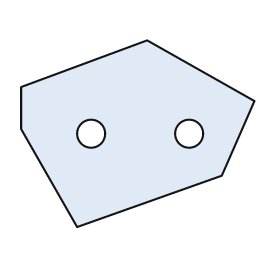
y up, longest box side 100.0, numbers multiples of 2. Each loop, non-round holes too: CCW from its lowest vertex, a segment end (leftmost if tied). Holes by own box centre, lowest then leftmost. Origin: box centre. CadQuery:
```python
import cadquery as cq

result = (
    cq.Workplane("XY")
    .moveTo(-26.0, -40.0)
    .lineTo(36.0, -18.0)
    .lineTo(50.0, 14.0)
    .lineTo(4.0, 40.0)
    .lineTo(-50.0, 20.0)
    .lineTo(-50.0, 2.0)
    .close()
    .moveTo(-20.0, 0.0)
    .circle(6.0)
    .moveTo(22.0, 0.0)
    .circle(6.0)
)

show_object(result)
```